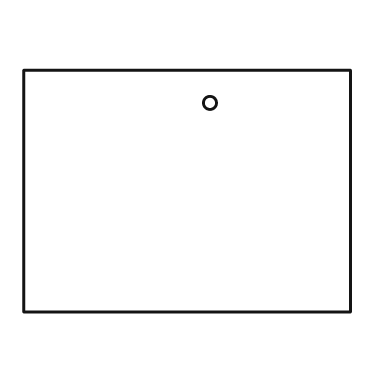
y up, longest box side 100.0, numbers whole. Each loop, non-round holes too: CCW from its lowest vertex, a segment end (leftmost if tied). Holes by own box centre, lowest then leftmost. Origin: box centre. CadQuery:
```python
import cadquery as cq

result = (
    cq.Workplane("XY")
    .moveTo(-50.0, -37.0)
    .lineTo(50.0, -37.0)
    .lineTo(50.0, 37.0)
    .lineTo(-50.0, 37.0)
    .close()
    .moveTo(7.0, 27.0)
    .circle(2.0)
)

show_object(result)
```